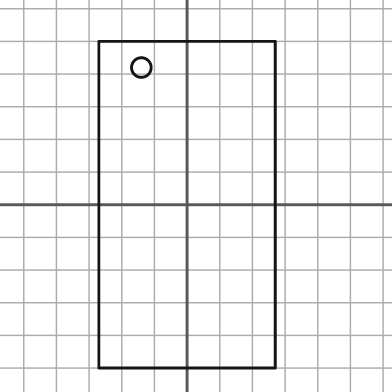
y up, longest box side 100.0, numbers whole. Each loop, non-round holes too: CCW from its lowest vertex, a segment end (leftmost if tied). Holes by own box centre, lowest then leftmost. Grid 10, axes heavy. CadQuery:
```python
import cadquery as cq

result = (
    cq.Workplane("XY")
    .moveTo(-27.0, -50.0)
    .lineTo(27.0, -50.0)
    .lineTo(27.0, 50.0)
    .lineTo(-27.0, 50.0)
    .close()
    .moveTo(-14.0, 42.0)
    .circle(3.0)
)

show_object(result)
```